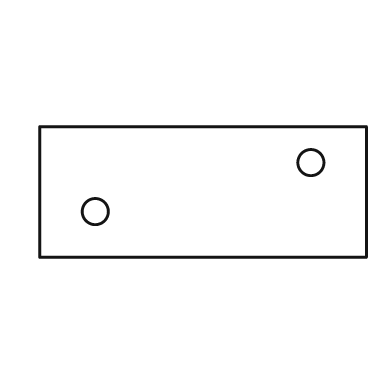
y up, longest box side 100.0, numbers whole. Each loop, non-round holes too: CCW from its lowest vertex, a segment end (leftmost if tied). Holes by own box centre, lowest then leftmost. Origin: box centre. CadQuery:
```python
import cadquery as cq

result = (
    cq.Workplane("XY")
    .moveTo(-50.0, -20.0)
    .lineTo(50.0, -20.0)
    .lineTo(50.0, 20.0)
    .lineTo(-50.0, 20.0)
    .close()
    .moveTo(-33.0, -6.0)
    .circle(4.0)
    .moveTo(33.0, 9.0)
    .circle(4.0)
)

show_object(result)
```